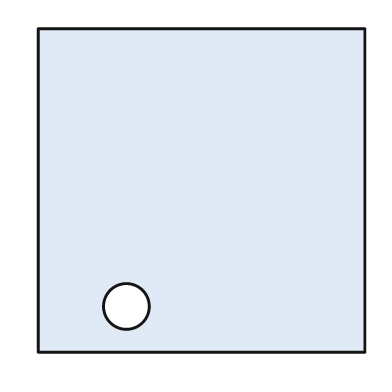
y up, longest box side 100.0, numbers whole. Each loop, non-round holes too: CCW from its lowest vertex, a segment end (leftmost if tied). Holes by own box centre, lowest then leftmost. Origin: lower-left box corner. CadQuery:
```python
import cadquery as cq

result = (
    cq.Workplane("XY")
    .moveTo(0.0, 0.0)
    .lineTo(100.0, 0.0)
    .lineTo(100.0, 99.0)
    .lineTo(0.0, 99.0)
    .close()
    .moveTo(27.0, 14.0)
    .circle(7.0)
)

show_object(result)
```